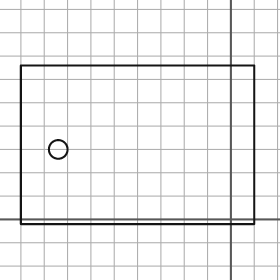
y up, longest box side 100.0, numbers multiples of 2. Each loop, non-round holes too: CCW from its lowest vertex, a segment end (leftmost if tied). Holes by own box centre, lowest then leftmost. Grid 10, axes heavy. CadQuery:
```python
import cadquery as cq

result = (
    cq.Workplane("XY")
    .moveTo(-90.0, -2.0)
    .lineTo(10.0, -2.0)
    .lineTo(10.0, 66.0)
    .lineTo(-90.0, 66.0)
    .close()
    .moveTo(-74.0, 30.0)
    .circle(4.0)
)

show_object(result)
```